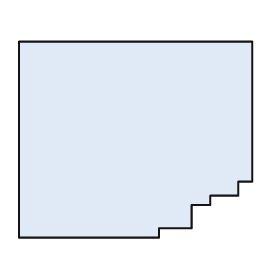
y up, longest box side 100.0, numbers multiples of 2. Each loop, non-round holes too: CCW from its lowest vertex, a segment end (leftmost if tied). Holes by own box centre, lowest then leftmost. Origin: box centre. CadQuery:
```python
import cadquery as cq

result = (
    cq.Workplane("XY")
    .moveTo(-50.0, -42.0)
    .lineTo(10.0, -42.0)
    .lineTo(10.0, -38.0)
    .lineTo(24.0, -38.0)
    .lineTo(24.0, -28.0)
    .lineTo(32.0, -28.0)
    .lineTo(32.0, -24.0)
    .lineTo(44.0, -24.0)
    .lineTo(44.0, -18.0)
    .lineTo(50.0, -18.0)
    .lineTo(50.0, 42.0)
    .lineTo(-50.0, 42.0)
    .close()
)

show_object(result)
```